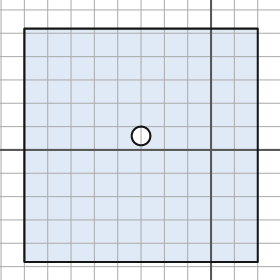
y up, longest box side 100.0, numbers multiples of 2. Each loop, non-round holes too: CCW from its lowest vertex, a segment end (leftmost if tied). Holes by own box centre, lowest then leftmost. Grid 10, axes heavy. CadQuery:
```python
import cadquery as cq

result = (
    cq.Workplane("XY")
    .moveTo(-80.0, -48.0)
    .lineTo(20.0, -48.0)
    .lineTo(20.0, 52.0)
    .lineTo(-80.0, 52.0)
    .close()
    .moveTo(-30.0, 6.0)
    .circle(4.0)
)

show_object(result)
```